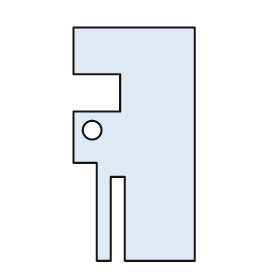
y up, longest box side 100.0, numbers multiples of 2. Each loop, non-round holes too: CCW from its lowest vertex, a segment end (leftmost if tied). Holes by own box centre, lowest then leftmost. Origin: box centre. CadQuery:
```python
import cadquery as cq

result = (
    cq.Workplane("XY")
    .moveTo(-16.0, -50.0)
    .lineTo(-10.0, -50.0)
    .lineTo(-10.0, -14.0)
    .lineTo(-4.0, -14.0)
    .lineTo(-4.0, -50.0)
    .lineTo(26.0, -50.0)
    .lineTo(26.0, 50.0)
    .lineTo(-26.0, 50.0)
    .lineTo(-26.0, 30.0)
    .lineTo(-6.0, 30.0)
    .lineTo(-6.0, 14.0)
    .lineTo(-26.0, 14.0)
    .lineTo(-26.0, -8.0)
    .lineTo(-16.0, -8.0)
    .close()
    .moveTo(-18.0, 6.0)
    .circle(4.0)
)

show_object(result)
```